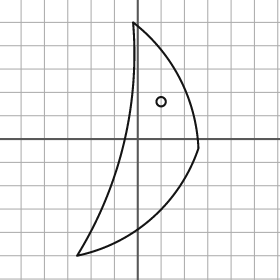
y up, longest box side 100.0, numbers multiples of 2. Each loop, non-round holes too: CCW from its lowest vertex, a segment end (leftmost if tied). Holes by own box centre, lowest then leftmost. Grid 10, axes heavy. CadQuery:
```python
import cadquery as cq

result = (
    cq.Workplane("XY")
    .moveTo(-26.0, -50.0)
    .threePointArc((6.0, -34.0), (26.0, -4.0))
    .threePointArc((18.0, 26.0), (-2.0, 50.0))
    .threePointArc((-6.0, -2.0), (-26.0, -50.0))
    .close()
    .moveTo(10.0, 16.0)
    .circle(2.0)
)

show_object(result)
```